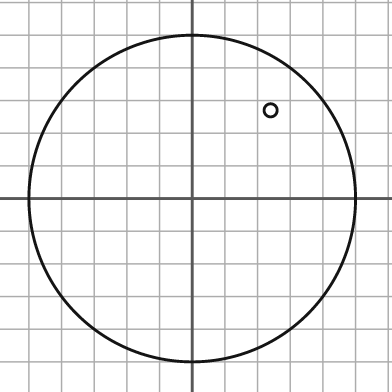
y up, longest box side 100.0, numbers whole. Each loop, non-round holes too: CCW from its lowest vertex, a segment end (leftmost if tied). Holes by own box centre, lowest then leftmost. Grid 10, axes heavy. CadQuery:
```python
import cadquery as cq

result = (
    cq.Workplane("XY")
    .moveTo(0.0, 0.0)
    .circle(50.0)
    .moveTo(24.0, 27.0)
    .circle(2.0)
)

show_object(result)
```